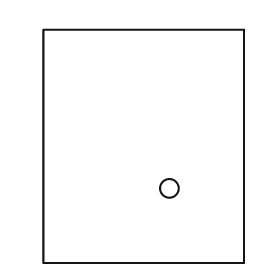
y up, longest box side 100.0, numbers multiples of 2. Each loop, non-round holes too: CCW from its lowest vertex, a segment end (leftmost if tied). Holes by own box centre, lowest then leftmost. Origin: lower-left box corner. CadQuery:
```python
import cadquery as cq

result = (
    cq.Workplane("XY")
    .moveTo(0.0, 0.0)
    .lineTo(86.0, 0.0)
    .lineTo(86.0, 100.0)
    .lineTo(0.0, 100.0)
    .close()
    .moveTo(54.0, 32.0)
    .circle(4.0)
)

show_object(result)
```